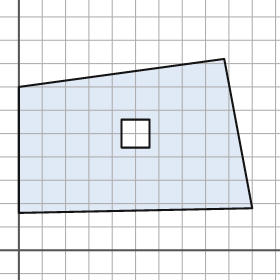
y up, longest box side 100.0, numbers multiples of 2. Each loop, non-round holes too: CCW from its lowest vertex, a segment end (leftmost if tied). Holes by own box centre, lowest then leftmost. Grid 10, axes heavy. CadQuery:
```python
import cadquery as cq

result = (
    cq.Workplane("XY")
    .moveTo(0.0, 16.0)
    .lineTo(100.0, 18.0)
    .lineTo(88.0, 82.0)
    .lineTo(0.0, 70.0)
    .close()
    .moveTo(44.0, 44.0)
    .lineTo(56.0, 44.0)
    .lineTo(56.0, 56.0)
    .lineTo(44.0, 56.0)
    .close()
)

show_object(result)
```